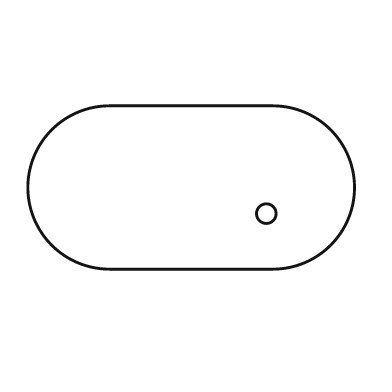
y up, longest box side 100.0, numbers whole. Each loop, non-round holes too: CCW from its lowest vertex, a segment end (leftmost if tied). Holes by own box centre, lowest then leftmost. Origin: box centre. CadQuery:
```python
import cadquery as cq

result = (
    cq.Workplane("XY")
    .moveTo(-25.0, -25.0)
    .lineTo(25.0, -25.0)
    .threePointArc((50.0, 0.0), (25.0, 25.0))
    .lineTo(-25.0, 25.0)
    .threePointArc((-50.0, 0.0), (-25.0, -25.0))
    .close()
    .moveTo(23.0, -8.0)
    .circle(3.0)
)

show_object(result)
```